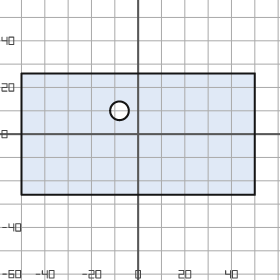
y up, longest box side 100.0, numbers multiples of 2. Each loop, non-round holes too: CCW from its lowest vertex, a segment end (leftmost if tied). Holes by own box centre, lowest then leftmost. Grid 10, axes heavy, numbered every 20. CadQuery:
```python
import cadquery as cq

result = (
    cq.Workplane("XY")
    .moveTo(-50.0, -26.0)
    .lineTo(50.0, -26.0)
    .lineTo(50.0, 26.0)
    .lineTo(-50.0, 26.0)
    .close()
    .moveTo(-8.0, 10.0)
    .circle(4.0)
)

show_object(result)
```